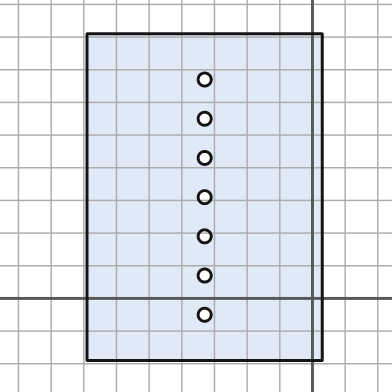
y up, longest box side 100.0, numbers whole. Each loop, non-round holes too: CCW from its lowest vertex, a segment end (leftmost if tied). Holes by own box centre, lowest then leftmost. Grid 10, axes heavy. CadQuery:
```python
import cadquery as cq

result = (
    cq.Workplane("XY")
    .moveTo(-69.0, -19.0)
    .lineTo(3.0, -19.0)
    .lineTo(3.0, 81.0)
    .lineTo(-69.0, 81.0)
    .close()
    .moveTo(-33.0, -5.0)
    .circle(2.0)
    .moveTo(-33.0, 7.0)
    .circle(2.0)
    .moveTo(-33.0, 19.0)
    .circle(2.0)
    .moveTo(-33.0, 31.0)
    .circle(2.0)
    .moveTo(-33.0, 43.0)
    .circle(2.0)
    .moveTo(-33.0, 55.0)
    .circle(2.0)
    .moveTo(-33.0, 67.0)
    .circle(2.0)
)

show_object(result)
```